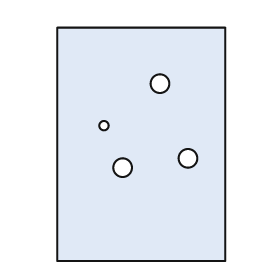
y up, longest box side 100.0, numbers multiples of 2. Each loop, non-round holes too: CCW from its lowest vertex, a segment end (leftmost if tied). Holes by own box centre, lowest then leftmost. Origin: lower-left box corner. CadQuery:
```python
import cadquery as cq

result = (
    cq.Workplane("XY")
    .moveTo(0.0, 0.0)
    .lineTo(72.0, 0.0)
    .lineTo(72.0, 100.0)
    .lineTo(0.0, 100.0)
    .close()
    .moveTo(28.0, 40.0)
    .circle(4.0)
    .moveTo(56.0, 44.0)
    .circle(4.0)
    .moveTo(20.0, 58.0)
    .circle(2.0)
    .moveTo(44.0, 76.0)
    .circle(4.0)
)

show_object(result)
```